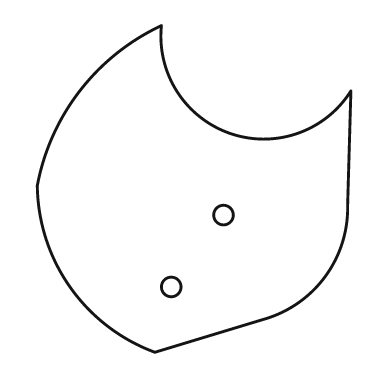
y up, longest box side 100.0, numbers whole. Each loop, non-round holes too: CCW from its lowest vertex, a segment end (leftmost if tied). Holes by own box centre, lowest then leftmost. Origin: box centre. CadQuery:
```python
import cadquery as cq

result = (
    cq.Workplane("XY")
    .moveTo(-12.0, -50.0)
    .lineTo(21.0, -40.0)
    .threePointArc((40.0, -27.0), (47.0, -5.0))
    .lineTo(48.0, 30.0)
    .threePointArc((11.0, 17.0), (-10.0, 50.0))
    .threePointArc((-35.0, 30.0), (-48.0, 1.0))
    .threePointArc((-38.0, -30.0), (-12.0, -50.0))
    .close()
    .moveTo(-7.0, -30.0)
    .circle(3.0)
    .moveTo(9.0, -8.0)
    .circle(3.0)
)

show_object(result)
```